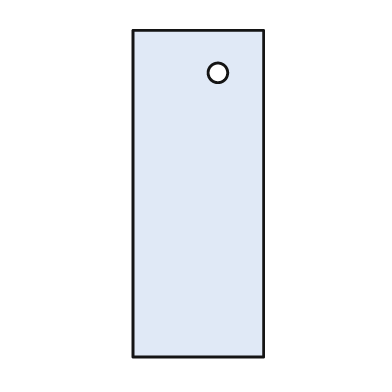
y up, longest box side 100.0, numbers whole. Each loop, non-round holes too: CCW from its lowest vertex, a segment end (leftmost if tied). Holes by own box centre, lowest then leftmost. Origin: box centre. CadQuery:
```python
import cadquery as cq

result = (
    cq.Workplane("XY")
    .moveTo(-20.0, -50.0)
    .lineTo(20.0, -50.0)
    .lineTo(20.0, 50.0)
    .lineTo(-20.0, 50.0)
    .close()
    .moveTo(6.0, 37.0)
    .circle(3.0)
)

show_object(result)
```